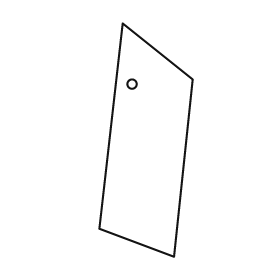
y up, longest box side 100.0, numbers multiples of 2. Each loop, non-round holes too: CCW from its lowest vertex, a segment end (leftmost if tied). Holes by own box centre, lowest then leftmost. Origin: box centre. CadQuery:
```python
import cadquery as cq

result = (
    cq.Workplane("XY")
    .moveTo(12.0, -50.0)
    .lineTo(20.0, 26.0)
    .lineTo(-10.0, 50.0)
    .lineTo(-20.0, -38.0)
    .close()
    .moveTo(-6.0, 24.0)
    .circle(2.0)
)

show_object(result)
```